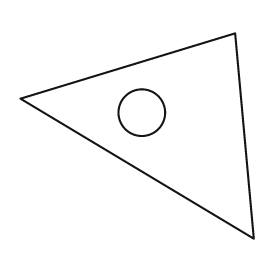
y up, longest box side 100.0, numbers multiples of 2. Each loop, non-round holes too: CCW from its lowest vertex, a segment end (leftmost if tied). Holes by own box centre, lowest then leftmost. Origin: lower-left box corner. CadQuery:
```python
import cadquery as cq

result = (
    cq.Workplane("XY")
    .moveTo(100.0, 0.0)
    .lineTo(92.0, 88.0)
    .lineTo(0.0, 60.0)
    .close()
    .moveTo(52.0, 54.0)
    .circle(10.0)
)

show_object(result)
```